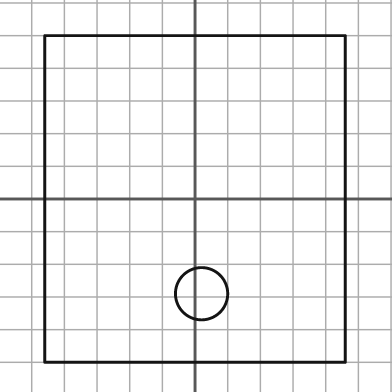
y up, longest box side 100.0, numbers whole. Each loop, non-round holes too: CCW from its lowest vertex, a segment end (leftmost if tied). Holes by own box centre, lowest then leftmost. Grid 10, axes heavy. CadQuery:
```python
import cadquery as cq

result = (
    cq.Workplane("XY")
    .moveTo(-46.0, -50.0)
    .lineTo(46.0, -50.0)
    .lineTo(46.0, 50.0)
    .lineTo(-46.0, 50.0)
    .close()
    .moveTo(2.0, -29.0)
    .circle(8.0)
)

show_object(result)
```